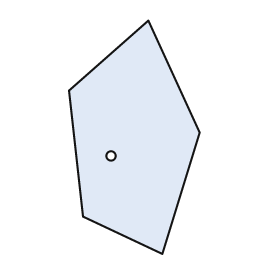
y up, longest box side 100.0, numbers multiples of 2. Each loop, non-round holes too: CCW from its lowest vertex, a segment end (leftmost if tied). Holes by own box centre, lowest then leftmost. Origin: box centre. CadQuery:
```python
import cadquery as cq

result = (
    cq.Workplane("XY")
    .moveTo(12.0, -50.0)
    .lineTo(28.0, 2.0)
    .lineTo(6.0, 50.0)
    .lineTo(-28.0, 20.0)
    .lineTo(-22.0, -34.0)
    .close()
    .moveTo(-10.0, -8.0)
    .circle(2.0)
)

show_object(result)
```